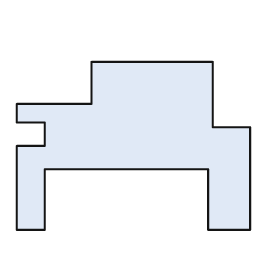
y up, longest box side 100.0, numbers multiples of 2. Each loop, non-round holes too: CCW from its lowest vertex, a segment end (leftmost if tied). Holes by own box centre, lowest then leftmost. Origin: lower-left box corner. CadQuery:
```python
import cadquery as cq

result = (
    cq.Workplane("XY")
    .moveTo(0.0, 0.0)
    .lineTo(12.0, 0.0)
    .lineTo(12.0, 26.0)
    .lineTo(82.0, 26.0)
    .lineTo(82.0, 0.0)
    .lineTo(100.0, 0.0)
    .lineTo(100.0, 44.0)
    .lineTo(84.0, 44.0)
    .lineTo(84.0, 72.0)
    .lineTo(32.0, 72.0)
    .lineTo(32.0, 54.0)
    .lineTo(0.0, 54.0)
    .lineTo(0.0, 46.0)
    .lineTo(12.0, 46.0)
    .lineTo(12.0, 36.0)
    .lineTo(0.0, 36.0)
    .close()
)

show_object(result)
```